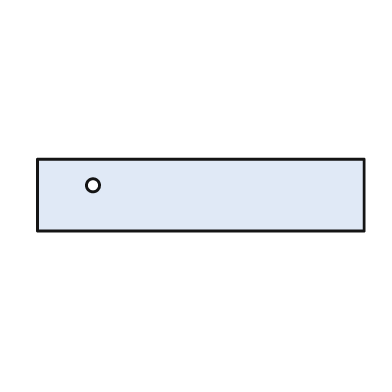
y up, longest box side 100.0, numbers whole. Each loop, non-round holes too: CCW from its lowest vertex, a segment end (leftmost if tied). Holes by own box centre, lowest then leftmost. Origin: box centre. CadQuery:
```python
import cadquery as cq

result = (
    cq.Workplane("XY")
    .moveTo(-50.0, -11.0)
    .lineTo(50.0, -11.0)
    .lineTo(50.0, 11.0)
    .lineTo(-50.0, 11.0)
    .close()
    .moveTo(-33.0, 3.0)
    .circle(2.0)
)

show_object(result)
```